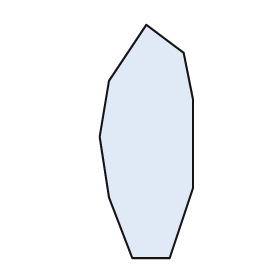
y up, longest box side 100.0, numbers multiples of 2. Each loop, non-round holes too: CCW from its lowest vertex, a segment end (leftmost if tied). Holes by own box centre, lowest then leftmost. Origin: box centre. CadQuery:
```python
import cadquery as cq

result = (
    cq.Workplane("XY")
    .moveTo(-6.0, -50.0)
    .lineTo(10.0, -50.0)
    .lineTo(20.0, -20.0)
    .lineTo(20.0, 18.0)
    .lineTo(16.0, 38.0)
    .lineTo(0.0, 50.0)
    .lineTo(-16.0, 26.0)
    .lineTo(-20.0, 2.0)
    .lineTo(-16.0, -24.0)
    .close()
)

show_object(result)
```